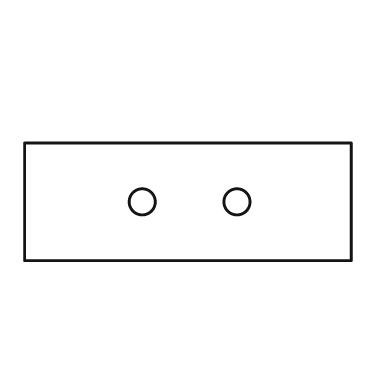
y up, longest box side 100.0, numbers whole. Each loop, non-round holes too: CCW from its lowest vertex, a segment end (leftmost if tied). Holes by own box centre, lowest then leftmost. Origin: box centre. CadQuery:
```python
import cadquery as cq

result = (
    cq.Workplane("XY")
    .moveTo(-50.0, -18.0)
    .lineTo(50.0, -18.0)
    .lineTo(50.0, 18.0)
    .lineTo(-50.0, 18.0)
    .close()
    .moveTo(-14.0, 0.0)
    .circle(4.0)
    .moveTo(15.0, 0.0)
    .circle(4.0)
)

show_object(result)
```